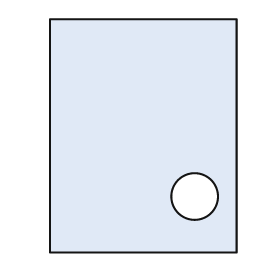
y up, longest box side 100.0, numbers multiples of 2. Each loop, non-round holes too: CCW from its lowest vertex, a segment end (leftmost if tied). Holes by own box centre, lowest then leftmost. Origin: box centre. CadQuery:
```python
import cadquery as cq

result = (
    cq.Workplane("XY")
    .moveTo(-40.0, -50.0)
    .lineTo(40.0, -50.0)
    .lineTo(40.0, 50.0)
    .lineTo(-40.0, 50.0)
    .close()
    .moveTo(22.0, -26.0)
    .circle(10.0)
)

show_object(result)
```